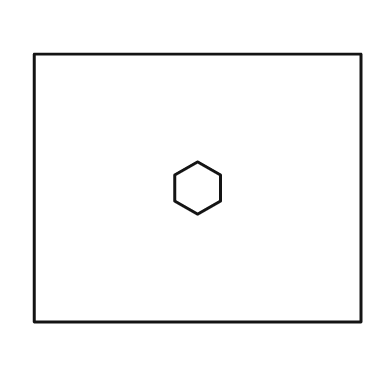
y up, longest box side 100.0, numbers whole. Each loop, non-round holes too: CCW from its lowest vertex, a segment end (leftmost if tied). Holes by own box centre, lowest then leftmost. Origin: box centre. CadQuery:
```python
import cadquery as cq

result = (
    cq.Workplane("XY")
    .moveTo(-50.0, -41.0)
    .lineTo(50.0, -41.0)
    .lineTo(50.0, 41.0)
    .lineTo(-50.0, 41.0)
    .close()
    .moveTo(0.0, -8.0)
    .lineTo(7.0, -4.0)
    .lineTo(7.0, 4.0)
    .lineTo(0.0, 8.0)
    .lineTo(-7.0, 4.0)
    .lineTo(-7.0, -4.0)
    .close()
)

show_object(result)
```